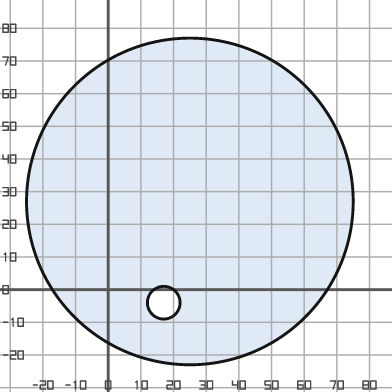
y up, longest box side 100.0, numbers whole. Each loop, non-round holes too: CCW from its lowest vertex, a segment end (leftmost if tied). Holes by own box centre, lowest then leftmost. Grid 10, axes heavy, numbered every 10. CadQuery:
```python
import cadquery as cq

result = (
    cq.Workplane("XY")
    .moveTo(25.0, 27.0)
    .circle(50.0)
    .moveTo(17.0, -4.0)
    .circle(5.0)
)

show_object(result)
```